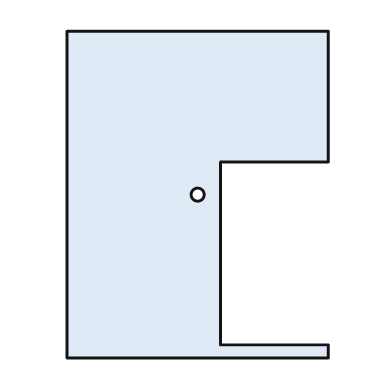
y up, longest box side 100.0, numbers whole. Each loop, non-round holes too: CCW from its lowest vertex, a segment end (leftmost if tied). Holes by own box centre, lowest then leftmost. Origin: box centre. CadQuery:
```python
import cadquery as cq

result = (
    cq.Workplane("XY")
    .moveTo(-40.0, -50.0)
    .lineTo(40.0, -50.0)
    .lineTo(40.0, -46.0)
    .lineTo(7.0, -46.0)
    .lineTo(7.0, 10.0)
    .lineTo(40.0, 10.0)
    .lineTo(40.0, 50.0)
    .lineTo(-40.0, 50.0)
    .close()
    .moveTo(0.0, 0.0)
    .circle(2.0)
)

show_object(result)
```